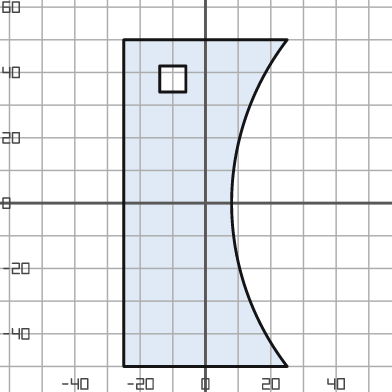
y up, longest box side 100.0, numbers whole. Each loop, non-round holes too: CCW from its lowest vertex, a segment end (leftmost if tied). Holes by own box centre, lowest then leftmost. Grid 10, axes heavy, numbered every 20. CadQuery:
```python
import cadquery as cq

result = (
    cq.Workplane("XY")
    .moveTo(-25.0, -50.0)
    .lineTo(25.0, -50.0)
    .threePointArc((8.0, 0.0), (25.0, 50.0))
    .lineTo(-25.0, 50.0)
    .close()
    .moveTo(-14.0, 34.0)
    .lineTo(-6.0, 34.0)
    .lineTo(-6.0, 42.0)
    .lineTo(-14.0, 42.0)
    .close()
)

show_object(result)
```